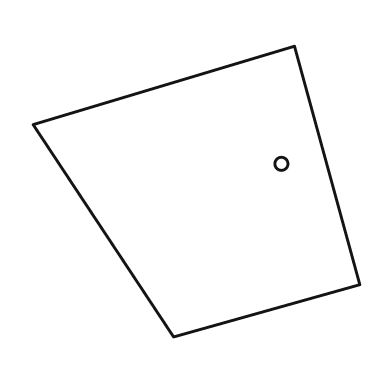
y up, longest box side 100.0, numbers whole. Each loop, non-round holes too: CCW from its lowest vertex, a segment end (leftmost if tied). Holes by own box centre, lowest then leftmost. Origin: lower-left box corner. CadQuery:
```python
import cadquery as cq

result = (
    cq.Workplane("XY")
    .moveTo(43.0, 0.0)
    .lineTo(100.0, 16.0)
    .lineTo(80.0, 89.0)
    .lineTo(0.0, 65.0)
    .close()
    .moveTo(76.0, 53.0)
    .circle(2.0)
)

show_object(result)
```